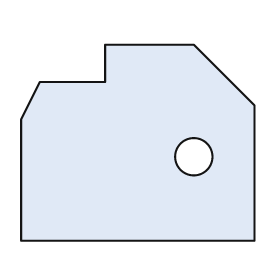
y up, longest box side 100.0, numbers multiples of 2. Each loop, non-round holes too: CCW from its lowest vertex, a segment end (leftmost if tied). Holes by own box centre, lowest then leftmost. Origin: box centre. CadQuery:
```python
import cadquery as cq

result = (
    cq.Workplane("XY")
    .moveTo(-50.0, -42.0)
    .lineTo(50.0, -42.0)
    .lineTo(50.0, 16.0)
    .lineTo(24.0, 42.0)
    .lineTo(-14.0, 42.0)
    .lineTo(-14.0, 26.0)
    .lineTo(-42.0, 26.0)
    .lineTo(-50.0, 10.0)
    .close()
    .moveTo(24.0, -6.0)
    .circle(8.0)
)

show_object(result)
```